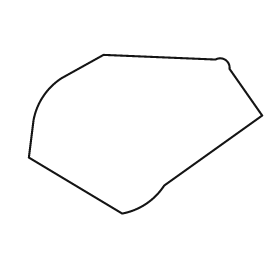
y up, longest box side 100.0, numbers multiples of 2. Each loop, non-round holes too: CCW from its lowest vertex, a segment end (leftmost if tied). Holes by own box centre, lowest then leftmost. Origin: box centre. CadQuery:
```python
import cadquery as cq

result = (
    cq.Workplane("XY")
    .moveTo(-10.0, -34.0)
    .threePointArc((0.0, -30.0), (8.0, -22.0))
    .lineTo(50.0, 8.0)
    .lineTo(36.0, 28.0)
    .threePointArc((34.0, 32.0), (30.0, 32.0))
    .lineTo(-18.0, 34.0)
    .lineTo(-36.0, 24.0)
    .threePointArc((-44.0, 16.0), (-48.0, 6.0))
    .lineTo(-50.0, -10.0)
    .close()
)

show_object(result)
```